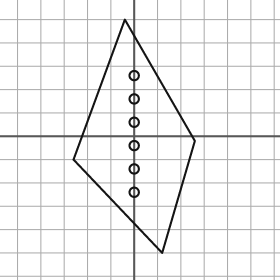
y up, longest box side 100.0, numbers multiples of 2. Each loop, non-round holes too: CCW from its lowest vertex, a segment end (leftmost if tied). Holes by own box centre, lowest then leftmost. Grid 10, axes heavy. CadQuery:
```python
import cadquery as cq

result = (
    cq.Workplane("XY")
    .moveTo(12.0, -50.0)
    .lineTo(26.0, -2.0)
    .lineTo(-4.0, 50.0)
    .lineTo(-26.0, -10.0)
    .close()
    .moveTo(0.0, -24.0)
    .circle(2.0)
    .moveTo(0.0, -14.0)
    .circle(2.0)
    .moveTo(0.0, -4.0)
    .circle(2.0)
    .moveTo(0.0, 6.0)
    .circle(2.0)
    .moveTo(0.0, 16.0)
    .circle(2.0)
    .moveTo(0.0, 26.0)
    .circle(2.0)
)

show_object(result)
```